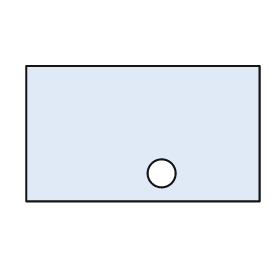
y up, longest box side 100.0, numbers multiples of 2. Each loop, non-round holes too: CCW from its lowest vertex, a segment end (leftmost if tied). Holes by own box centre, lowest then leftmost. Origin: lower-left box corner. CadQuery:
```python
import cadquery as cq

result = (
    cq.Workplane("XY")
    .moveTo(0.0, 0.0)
    .lineTo(100.0, 0.0)
    .lineTo(100.0, 58.0)
    .lineTo(0.0, 58.0)
    .close()
    .moveTo(58.0, 12.0)
    .circle(6.0)
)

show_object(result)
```